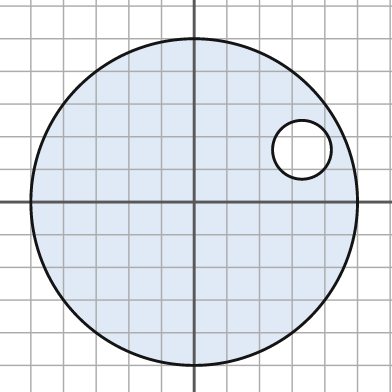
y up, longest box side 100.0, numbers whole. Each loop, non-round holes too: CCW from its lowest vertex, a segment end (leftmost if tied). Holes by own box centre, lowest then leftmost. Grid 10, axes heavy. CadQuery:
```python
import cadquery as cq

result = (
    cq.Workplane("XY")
    .moveTo(0.0, 0.0)
    .circle(50.0)
    .moveTo(33.0, 16.0)
    .circle(9.0)
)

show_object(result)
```